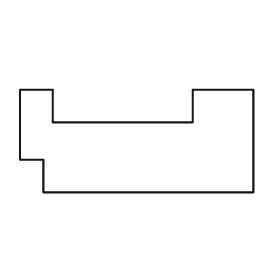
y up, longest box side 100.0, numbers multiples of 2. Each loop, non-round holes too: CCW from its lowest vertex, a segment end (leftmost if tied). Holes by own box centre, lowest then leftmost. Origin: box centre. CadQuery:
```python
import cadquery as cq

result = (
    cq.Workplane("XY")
    .moveTo(-40.0, -22.0)
    .lineTo(50.0, -22.0)
    .lineTo(50.0, 22.0)
    .lineTo(24.0, 22.0)
    .lineTo(24.0, 8.0)
    .lineTo(-36.0, 8.0)
    .lineTo(-36.0, 22.0)
    .lineTo(-50.0, 22.0)
    .lineTo(-50.0, -8.0)
    .lineTo(-40.0, -8.0)
    .close()
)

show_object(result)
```